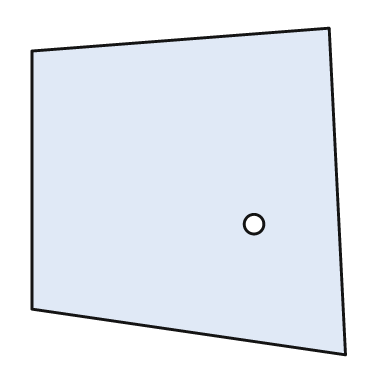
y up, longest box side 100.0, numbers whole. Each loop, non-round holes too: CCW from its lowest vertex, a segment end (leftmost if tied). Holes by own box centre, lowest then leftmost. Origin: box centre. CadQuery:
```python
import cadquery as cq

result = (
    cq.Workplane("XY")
    .moveTo(48.0, -50.0)
    .lineTo(43.0, 50.0)
    .lineTo(-48.0, 43.0)
    .lineTo(-48.0, -36.0)
    .close()
    .moveTo(20.0, -10.0)
    .circle(3.0)
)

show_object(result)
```